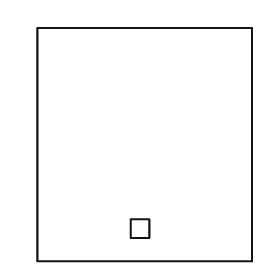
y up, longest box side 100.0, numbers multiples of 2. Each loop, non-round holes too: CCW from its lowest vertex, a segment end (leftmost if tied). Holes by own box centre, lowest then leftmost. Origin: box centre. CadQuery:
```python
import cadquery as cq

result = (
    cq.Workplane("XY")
    .moveTo(-46.0, -50.0)
    .lineTo(46.0, -50.0)
    .lineTo(46.0, 50.0)
    .lineTo(-46.0, 50.0)
    .close()
    .moveTo(-6.0, -40.0)
    .lineTo(2.0, -40.0)
    .lineTo(2.0, -32.0)
    .lineTo(-6.0, -32.0)
    .close()
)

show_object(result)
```